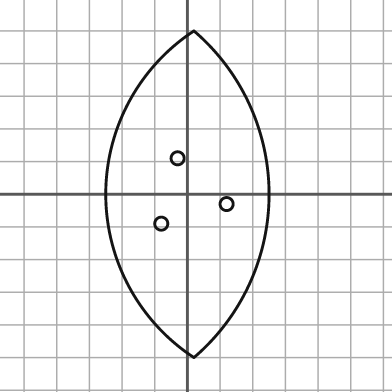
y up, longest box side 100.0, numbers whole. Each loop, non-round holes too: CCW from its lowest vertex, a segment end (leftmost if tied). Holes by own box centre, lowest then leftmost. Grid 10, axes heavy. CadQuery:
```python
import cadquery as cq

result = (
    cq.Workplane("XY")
    .moveTo(2.0, -50.0)
    .threePointArc((25.0, 0.0), (2.0, 50.0))
    .threePointArc((-25.0, 0.0), (2.0, -50.0))
    .close()
    .moveTo(-8.0, -9.0)
    .circle(2.0)
    .moveTo(12.0, -3.0)
    .circle(2.0)
    .moveTo(-3.0, 11.0)
    .circle(2.0)
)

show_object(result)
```